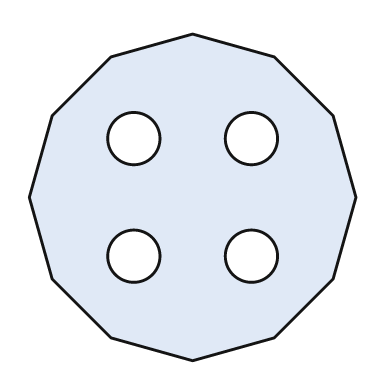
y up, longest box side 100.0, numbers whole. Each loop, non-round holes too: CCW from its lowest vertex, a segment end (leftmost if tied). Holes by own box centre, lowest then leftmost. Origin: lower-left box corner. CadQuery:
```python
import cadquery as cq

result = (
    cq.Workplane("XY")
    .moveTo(50.0, 0.0)
    .lineTo(75.0, 7.0)
    .lineTo(93.0, 25.0)
    .lineTo(100.0, 50.0)
    .lineTo(93.0, 75.0)
    .lineTo(75.0, 93.0)
    .lineTo(50.0, 100.0)
    .lineTo(25.0, 93.0)
    .lineTo(7.0, 75.0)
    .lineTo(0.0, 50.0)
    .lineTo(7.0, 25.0)
    .lineTo(25.0, 7.0)
    .close()
    .moveTo(32.0, 32.0)
    .circle(8.0)
    .moveTo(68.0, 32.0)
    .circle(8.0)
    .moveTo(32.0, 68.0)
    .circle(8.0)
    .moveTo(68.0, 68.0)
    .circle(8.0)
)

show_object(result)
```